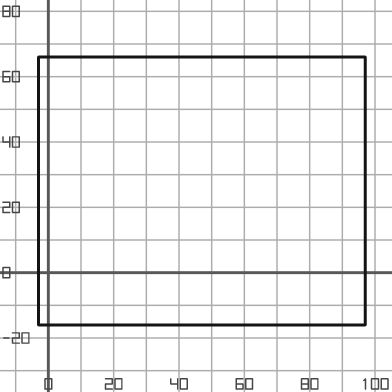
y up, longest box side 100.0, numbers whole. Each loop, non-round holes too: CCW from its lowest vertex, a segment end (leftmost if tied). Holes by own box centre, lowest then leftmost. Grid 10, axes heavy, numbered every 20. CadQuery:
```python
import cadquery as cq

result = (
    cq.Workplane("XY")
    .moveTo(-3.0, -16.0)
    .lineTo(97.0, -16.0)
    .lineTo(97.0, 66.0)
    .lineTo(-3.0, 66.0)
    .close()
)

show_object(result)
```